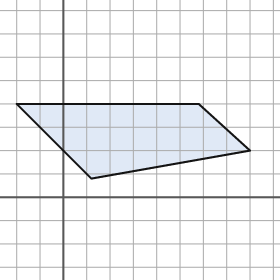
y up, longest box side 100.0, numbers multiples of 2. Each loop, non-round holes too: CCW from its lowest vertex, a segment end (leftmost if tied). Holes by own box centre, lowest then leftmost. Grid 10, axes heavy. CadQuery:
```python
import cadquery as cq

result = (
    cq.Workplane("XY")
    .moveTo(12.0, 8.0)
    .lineTo(80.0, 20.0)
    .lineTo(58.0, 40.0)
    .lineTo(-20.0, 40.0)
    .close()
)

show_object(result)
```